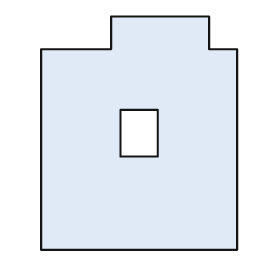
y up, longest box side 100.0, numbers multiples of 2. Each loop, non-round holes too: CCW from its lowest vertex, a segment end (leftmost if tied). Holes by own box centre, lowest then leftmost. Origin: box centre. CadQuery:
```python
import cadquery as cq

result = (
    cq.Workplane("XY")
    .moveTo(-42.0, -50.0)
    .lineTo(42.0, -50.0)
    .lineTo(42.0, 36.0)
    .lineTo(30.0, 36.0)
    .lineTo(30.0, 50.0)
    .lineTo(-12.0, 50.0)
    .lineTo(-12.0, 36.0)
    .lineTo(-42.0, 36.0)
    .close()
    .moveTo(-8.0, -10.0)
    .lineTo(8.0, -10.0)
    .lineTo(8.0, 10.0)
    .lineTo(-8.0, 10.0)
    .close()
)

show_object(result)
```